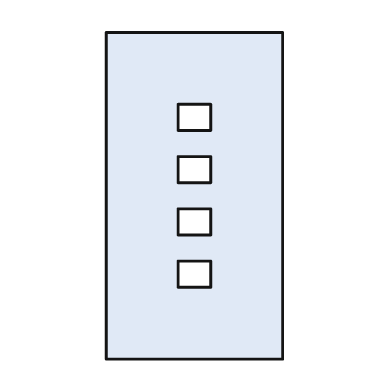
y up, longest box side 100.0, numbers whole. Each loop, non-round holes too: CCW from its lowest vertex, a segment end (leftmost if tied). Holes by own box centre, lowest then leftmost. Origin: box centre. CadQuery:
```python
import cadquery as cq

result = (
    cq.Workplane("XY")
    .moveTo(-27.0, -50.0)
    .lineTo(27.0, -50.0)
    .lineTo(27.0, 50.0)
    .lineTo(-27.0, 50.0)
    .close()
    .moveTo(-5.0, -28.0)
    .lineTo(5.0, -28.0)
    .lineTo(5.0, -20.0)
    .lineTo(-5.0, -20.0)
    .close()
    .moveTo(-5.0, -12.0)
    .lineTo(5.0, -12.0)
    .lineTo(5.0, -4.0)
    .lineTo(-5.0, -4.0)
    .close()
    .moveTo(-5.0, 4.0)
    .lineTo(5.0, 4.0)
    .lineTo(5.0, 12.0)
    .lineTo(-5.0, 12.0)
    .close()
    .moveTo(-5.0, 20.0)
    .lineTo(5.0, 20.0)
    .lineTo(5.0, 28.0)
    .lineTo(-5.0, 28.0)
    .close()
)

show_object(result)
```